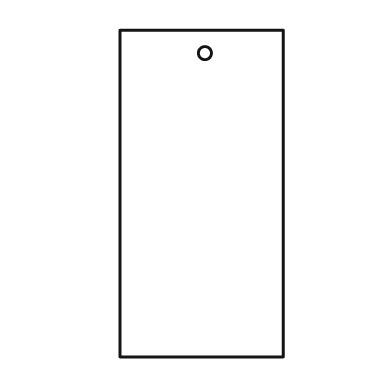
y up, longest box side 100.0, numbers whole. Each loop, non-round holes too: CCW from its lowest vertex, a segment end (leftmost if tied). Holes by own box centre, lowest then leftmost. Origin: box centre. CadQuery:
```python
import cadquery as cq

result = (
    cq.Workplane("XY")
    .moveTo(-25.0, -50.0)
    .lineTo(25.0, -50.0)
    .lineTo(25.0, 50.0)
    .lineTo(-25.0, 50.0)
    .close()
    .moveTo(1.0, 43.0)
    .circle(2.0)
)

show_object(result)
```